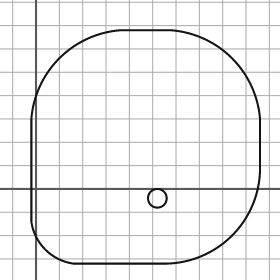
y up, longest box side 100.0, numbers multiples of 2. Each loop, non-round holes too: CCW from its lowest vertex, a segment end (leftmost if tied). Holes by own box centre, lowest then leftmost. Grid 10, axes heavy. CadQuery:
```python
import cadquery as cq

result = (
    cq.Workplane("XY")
    .moveTo(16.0, -32.0)
    .lineTo(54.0, -32.0)
    .threePointArc((84.0, -20.0), (96.0, 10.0))
    .lineTo(96.0, 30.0)
    .threePointArc((84.0, 56.0), (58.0, 68.0))
    .lineTo(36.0, 68.0)
    .threePointArc((10.0, 56.0), (-2.0, 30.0))
    .lineTo(-2.0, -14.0)
    .threePointArc((4.0, -26.0), (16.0, -32.0))
    .close()
    .moveTo(52.0, -4.0)
    .circle(4.0)
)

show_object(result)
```